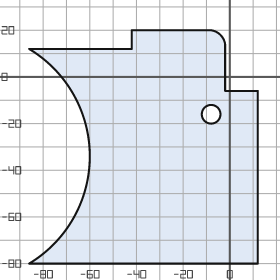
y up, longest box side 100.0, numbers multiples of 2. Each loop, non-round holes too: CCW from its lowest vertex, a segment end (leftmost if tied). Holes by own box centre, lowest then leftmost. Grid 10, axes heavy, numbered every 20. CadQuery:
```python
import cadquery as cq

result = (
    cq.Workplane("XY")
    .moveTo(-86.0, -80.0)
    .lineTo(12.0, -80.0)
    .lineTo(12.0, -6.0)
    .lineTo(-2.0, -6.0)
    .lineTo(-2.0, 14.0)
    .threePointArc((-4.0, 18.0), (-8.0, 20.0))
    .lineTo(-42.0, 20.0)
    .lineTo(-42.0, 12.0)
    .lineTo(-86.0, 12.0)
    .threePointArc((-60.0, -34.0), (-86.0, -80.0))
    .close()
    .moveTo(-8.0, -16.0)
    .circle(4.0)
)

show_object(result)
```